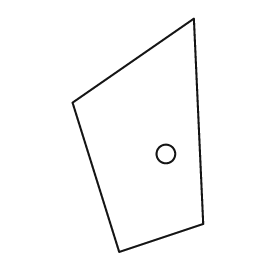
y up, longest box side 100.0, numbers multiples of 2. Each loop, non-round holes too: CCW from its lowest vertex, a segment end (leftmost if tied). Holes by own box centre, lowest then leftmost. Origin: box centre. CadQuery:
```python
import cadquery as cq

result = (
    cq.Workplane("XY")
    .moveTo(-8.0, -50.0)
    .lineTo(28.0, -38.0)
    .lineTo(24.0, 50.0)
    .lineTo(-28.0, 14.0)
    .close()
    .moveTo(12.0, -8.0)
    .circle(4.0)
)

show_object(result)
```